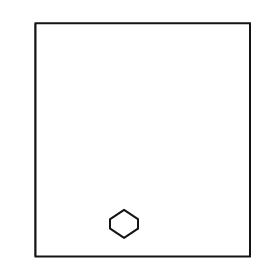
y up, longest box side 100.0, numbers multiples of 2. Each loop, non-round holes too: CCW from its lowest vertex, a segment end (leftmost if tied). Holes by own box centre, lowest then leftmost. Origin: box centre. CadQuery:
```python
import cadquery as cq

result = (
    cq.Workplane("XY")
    .moveTo(-46.0, -50.0)
    .lineTo(46.0, -50.0)
    .lineTo(46.0, 50.0)
    .lineTo(-46.0, 50.0)
    .close()
    .moveTo(-8.0, -42.0)
    .lineTo(-2.0, -38.0)
    .lineTo(-2.0, -34.0)
    .lineTo(-8.0, -30.0)
    .lineTo(-14.0, -34.0)
    .lineTo(-14.0, -38.0)
    .close()
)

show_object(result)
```